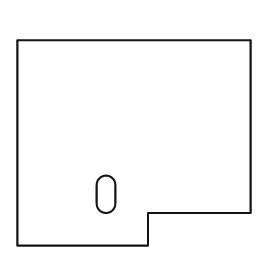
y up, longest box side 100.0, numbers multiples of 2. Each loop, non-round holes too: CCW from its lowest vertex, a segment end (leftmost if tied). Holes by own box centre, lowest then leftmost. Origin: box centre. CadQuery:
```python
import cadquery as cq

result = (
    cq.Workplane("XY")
    .moveTo(-50.0, -44.0)
    .lineTo(6.0, -44.0)
    .lineTo(6.0, -30.0)
    .lineTo(50.0, -30.0)
    .lineTo(50.0, 44.0)
    .lineTo(-50.0, 44.0)
    .close()
    .moveTo(-16.0, -26.0)
    .threePointArc((-12.0, -30.0), (-8.0, -26.0))
    .lineTo(-8.0, -18.0)
    .threePointArc((-12.0, -14.0), (-16.0, -18.0))
    .close()
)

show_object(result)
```